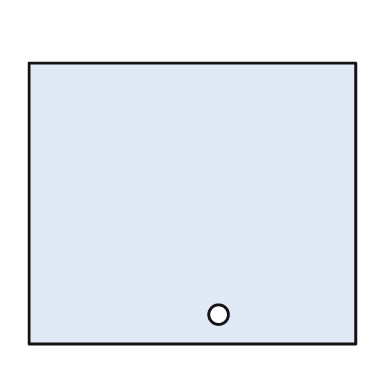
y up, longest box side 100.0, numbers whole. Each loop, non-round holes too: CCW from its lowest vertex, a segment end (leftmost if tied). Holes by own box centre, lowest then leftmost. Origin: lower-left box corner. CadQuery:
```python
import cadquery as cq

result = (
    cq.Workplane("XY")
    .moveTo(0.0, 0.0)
    .lineTo(100.0, 0.0)
    .lineTo(100.0, 86.0)
    .lineTo(0.0, 86.0)
    .close()
    .moveTo(58.0, 9.0)
    .circle(3.0)
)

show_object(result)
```